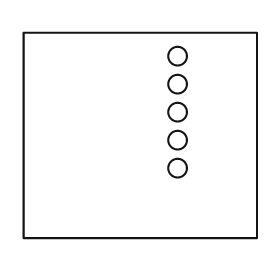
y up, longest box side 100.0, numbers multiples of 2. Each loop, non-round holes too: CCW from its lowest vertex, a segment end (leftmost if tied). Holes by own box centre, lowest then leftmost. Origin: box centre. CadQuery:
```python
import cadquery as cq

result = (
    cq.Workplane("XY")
    .moveTo(-50.0, -44.0)
    .lineTo(50.0, -44.0)
    .lineTo(50.0, 44.0)
    .lineTo(-50.0, 44.0)
    .close()
    .moveTo(16.0, -14.0)
    .circle(4.0)
    .moveTo(16.0, -2.0)
    .circle(4.0)
    .moveTo(16.0, 10.0)
    .circle(4.0)
    .moveTo(16.0, 22.0)
    .circle(4.0)
    .moveTo(16.0, 34.0)
    .circle(4.0)
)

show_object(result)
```